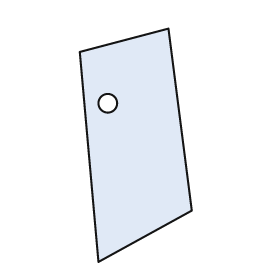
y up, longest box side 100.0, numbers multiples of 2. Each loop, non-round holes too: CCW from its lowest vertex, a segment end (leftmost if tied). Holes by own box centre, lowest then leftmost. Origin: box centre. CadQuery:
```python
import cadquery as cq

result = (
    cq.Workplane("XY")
    .moveTo(-16.0, -50.0)
    .lineTo(24.0, -28.0)
    .lineTo(14.0, 50.0)
    .lineTo(-24.0, 40.0)
    .close()
    .moveTo(-12.0, 18.0)
    .circle(4.0)
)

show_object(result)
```